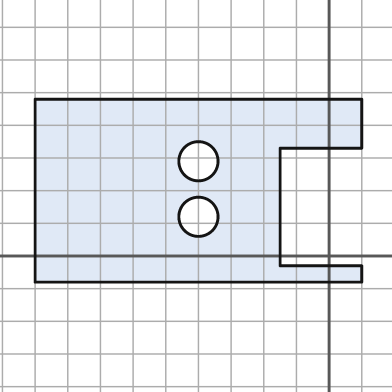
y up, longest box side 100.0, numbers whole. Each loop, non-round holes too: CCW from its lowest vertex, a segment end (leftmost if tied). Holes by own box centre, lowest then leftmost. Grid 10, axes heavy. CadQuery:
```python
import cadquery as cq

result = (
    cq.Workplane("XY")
    .moveTo(-90.0, -8.0)
    .lineTo(10.0, -8.0)
    .lineTo(10.0, -3.0)
    .lineTo(-15.0, -3.0)
    .lineTo(-15.0, 33.0)
    .lineTo(10.0, 33.0)
    .lineTo(10.0, 48.0)
    .lineTo(-90.0, 48.0)
    .close()
    .moveTo(-40.0, 12.0)
    .circle(6.0)
    .moveTo(-40.0, 29.0)
    .circle(6.0)
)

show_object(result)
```